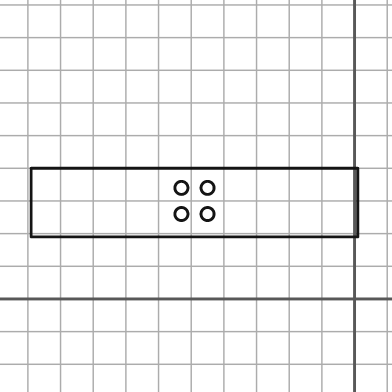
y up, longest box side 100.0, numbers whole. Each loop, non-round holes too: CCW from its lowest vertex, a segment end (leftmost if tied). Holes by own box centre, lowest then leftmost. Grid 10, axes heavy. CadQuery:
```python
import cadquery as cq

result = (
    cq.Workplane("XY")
    .moveTo(-99.0, 19.0)
    .lineTo(1.0, 19.0)
    .lineTo(1.0, 40.0)
    .lineTo(-99.0, 40.0)
    .close()
    .moveTo(-53.0, 26.0)
    .circle(2.0)
    .moveTo(-45.0, 26.0)
    .circle(2.0)
    .moveTo(-53.0, 34.0)
    .circle(2.0)
    .moveTo(-45.0, 34.0)
    .circle(2.0)
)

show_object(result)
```